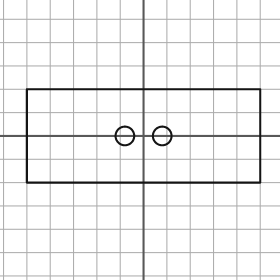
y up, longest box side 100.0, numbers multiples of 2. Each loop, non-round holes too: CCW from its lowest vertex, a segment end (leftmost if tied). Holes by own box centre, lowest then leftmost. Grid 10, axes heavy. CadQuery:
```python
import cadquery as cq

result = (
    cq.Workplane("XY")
    .moveTo(-50.0, -20.0)
    .lineTo(50.0, -20.0)
    .lineTo(50.0, 20.0)
    .lineTo(-50.0, 20.0)
    .close()
    .moveTo(-8.0, 0.0)
    .circle(4.0)
    .moveTo(8.0, 0.0)
    .circle(4.0)
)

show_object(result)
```